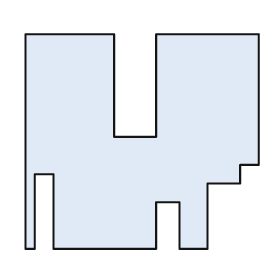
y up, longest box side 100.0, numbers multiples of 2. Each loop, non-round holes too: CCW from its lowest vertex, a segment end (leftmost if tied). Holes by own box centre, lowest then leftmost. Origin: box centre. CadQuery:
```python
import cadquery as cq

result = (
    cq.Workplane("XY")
    .moveTo(-50.0, -46.0)
    .lineTo(-46.0, -46.0)
    .lineTo(-46.0, -14.0)
    .lineTo(-38.0, -14.0)
    .lineTo(-38.0, -46.0)
    .lineTo(6.0, -46.0)
    .lineTo(6.0, -26.0)
    .lineTo(16.0, -26.0)
    .lineTo(16.0, -46.0)
    .lineTo(28.0, -46.0)
    .lineTo(28.0, -18.0)
    .lineTo(42.0, -18.0)
    .lineTo(42.0, -10.0)
    .lineTo(50.0, -10.0)
    .lineTo(50.0, 46.0)
    .lineTo(6.0, 46.0)
    .lineTo(6.0, 2.0)
    .lineTo(-12.0, 2.0)
    .lineTo(-12.0, 46.0)
    .lineTo(-50.0, 46.0)
    .close()
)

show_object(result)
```